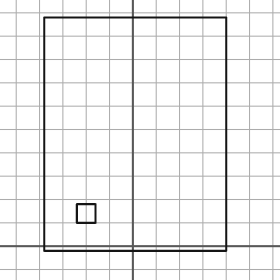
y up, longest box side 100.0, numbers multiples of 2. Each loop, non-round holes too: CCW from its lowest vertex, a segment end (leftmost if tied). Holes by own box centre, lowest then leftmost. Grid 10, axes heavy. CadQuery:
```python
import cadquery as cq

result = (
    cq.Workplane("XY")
    .moveTo(-38.0, -2.0)
    .lineTo(40.0, -2.0)
    .lineTo(40.0, 98.0)
    .lineTo(-38.0, 98.0)
    .close()
    .moveTo(-24.0, 10.0)
    .lineTo(-16.0, 10.0)
    .lineTo(-16.0, 18.0)
    .lineTo(-24.0, 18.0)
    .close()
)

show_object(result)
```